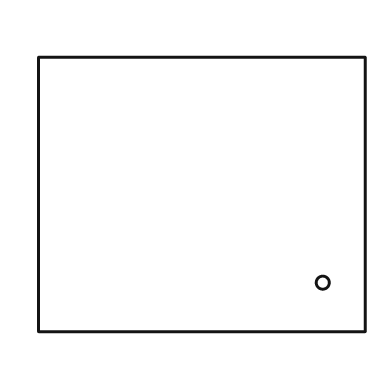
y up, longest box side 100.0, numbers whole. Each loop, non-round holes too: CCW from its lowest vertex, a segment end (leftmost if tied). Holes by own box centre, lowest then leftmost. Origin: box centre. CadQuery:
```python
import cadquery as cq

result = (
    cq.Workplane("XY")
    .moveTo(-50.0, -42.0)
    .lineTo(50.0, -42.0)
    .lineTo(50.0, 42.0)
    .lineTo(-50.0, 42.0)
    .close()
    .moveTo(37.0, -27.0)
    .circle(2.0)
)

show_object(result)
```